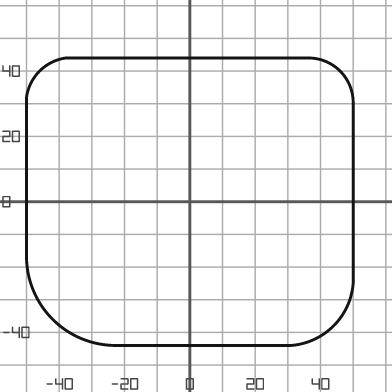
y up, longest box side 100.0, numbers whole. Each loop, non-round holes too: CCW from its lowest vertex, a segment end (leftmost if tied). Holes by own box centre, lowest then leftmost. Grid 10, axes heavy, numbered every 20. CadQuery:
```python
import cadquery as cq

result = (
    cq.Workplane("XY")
    .moveTo(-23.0, -44.0)
    .lineTo(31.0, -44.0)
    .threePointArc((44.0, -38.0), (50.0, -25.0))
    .lineTo(50.0, 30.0)
    .threePointArc((46.0, 40.0), (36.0, 44.0))
    .lineTo(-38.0, 44.0)
    .threePointArc((-46.0, 40.0), (-50.0, 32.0))
    .lineTo(-50.0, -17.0)
    .threePointArc((-42.0, -36.0), (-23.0, -44.0))
    .close()
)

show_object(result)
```